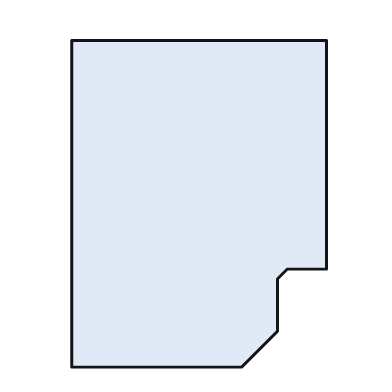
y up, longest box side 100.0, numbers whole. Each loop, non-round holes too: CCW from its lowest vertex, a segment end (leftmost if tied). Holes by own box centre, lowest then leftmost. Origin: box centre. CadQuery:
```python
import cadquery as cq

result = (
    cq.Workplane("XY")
    .moveTo(-39.0, -50.0)
    .lineTo(13.0, -50.0)
    .lineTo(24.0, -39.0)
    .lineTo(24.0, -23.0)
    .lineTo(27.0, -20.0)
    .lineTo(39.0, -20.0)
    .lineTo(39.0, 50.0)
    .lineTo(-39.0, 50.0)
    .close()
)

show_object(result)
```